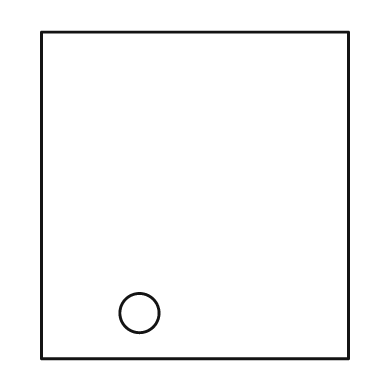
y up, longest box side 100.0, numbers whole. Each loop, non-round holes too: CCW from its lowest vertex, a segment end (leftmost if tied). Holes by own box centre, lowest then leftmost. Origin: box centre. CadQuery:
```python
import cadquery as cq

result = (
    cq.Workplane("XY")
    .moveTo(-47.0, -50.0)
    .lineTo(47.0, -50.0)
    .lineTo(47.0, 50.0)
    .lineTo(-47.0, 50.0)
    .close()
    .moveTo(-17.0, -36.0)
    .circle(6.0)
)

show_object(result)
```